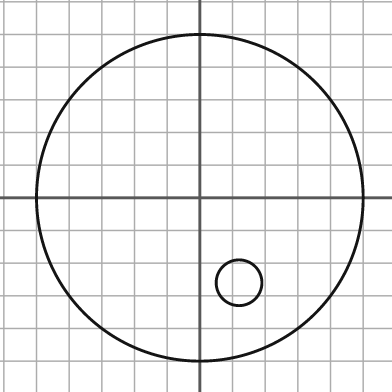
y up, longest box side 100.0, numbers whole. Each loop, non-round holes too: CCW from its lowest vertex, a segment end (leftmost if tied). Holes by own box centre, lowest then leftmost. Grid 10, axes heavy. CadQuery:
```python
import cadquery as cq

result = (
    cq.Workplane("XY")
    .moveTo(0.0, 0.0)
    .circle(50.0)
    .moveTo(12.0, -26.0)
    .circle(7.0)
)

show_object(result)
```